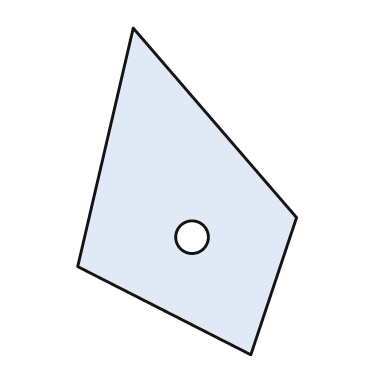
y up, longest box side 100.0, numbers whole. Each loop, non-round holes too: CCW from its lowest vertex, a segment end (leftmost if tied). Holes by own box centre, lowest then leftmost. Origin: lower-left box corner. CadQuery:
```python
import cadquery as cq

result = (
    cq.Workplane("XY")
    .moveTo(53.0, 0.0)
    .lineTo(67.0, 42.0)
    .lineTo(17.0, 100.0)
    .lineTo(0.0, 27.0)
    .close()
    .moveTo(35.0, 36.0)
    .circle(5.0)
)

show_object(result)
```